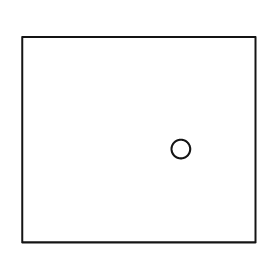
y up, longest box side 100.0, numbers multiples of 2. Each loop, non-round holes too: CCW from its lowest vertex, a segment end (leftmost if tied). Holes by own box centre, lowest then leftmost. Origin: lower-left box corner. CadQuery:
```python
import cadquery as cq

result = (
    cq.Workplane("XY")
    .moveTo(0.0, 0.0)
    .lineTo(100.0, 0.0)
    .lineTo(100.0, 88.0)
    .lineTo(0.0, 88.0)
    .close()
    .moveTo(68.0, 40.0)
    .circle(4.0)
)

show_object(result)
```